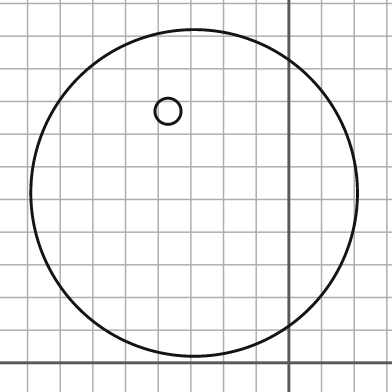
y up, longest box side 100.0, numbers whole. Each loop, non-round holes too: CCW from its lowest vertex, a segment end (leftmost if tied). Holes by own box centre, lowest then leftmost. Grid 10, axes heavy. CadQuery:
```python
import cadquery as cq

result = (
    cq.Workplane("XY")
    .moveTo(-29.0, 52.0)
    .circle(50.0)
    .moveTo(-37.0, 77.0)
    .circle(4.0)
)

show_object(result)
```